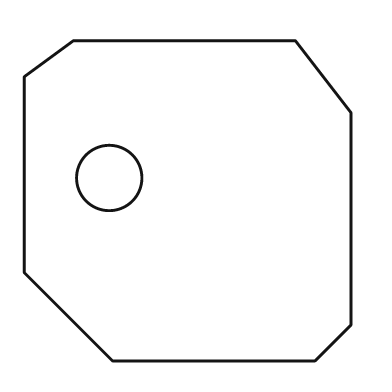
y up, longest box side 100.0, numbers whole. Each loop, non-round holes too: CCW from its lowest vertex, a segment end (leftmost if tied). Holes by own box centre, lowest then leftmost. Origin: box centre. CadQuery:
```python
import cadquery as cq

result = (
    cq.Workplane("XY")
    .moveTo(-23.0, -49.0)
    .lineTo(39.0, -49.0)
    .lineTo(50.0, -38.0)
    .lineTo(50.0, 27.0)
    .lineTo(33.0, 49.0)
    .lineTo(-35.0, 49.0)
    .lineTo(-50.0, 38.0)
    .lineTo(-50.0, -22.0)
    .close()
    .moveTo(-24.0, 7.0)
    .circle(10.0)
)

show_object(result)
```